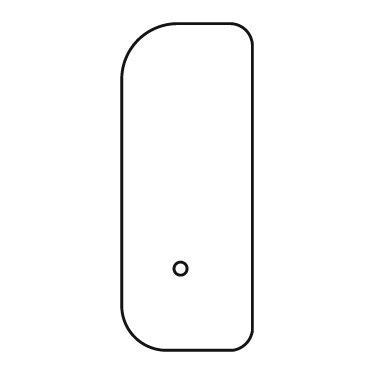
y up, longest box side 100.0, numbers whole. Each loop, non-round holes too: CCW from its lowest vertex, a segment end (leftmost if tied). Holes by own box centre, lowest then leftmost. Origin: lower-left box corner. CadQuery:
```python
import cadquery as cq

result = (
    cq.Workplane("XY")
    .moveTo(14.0, 0.0)
    .lineTo(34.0, 0.0)
    .threePointArc((38.0, 2.0), (40.0, 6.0))
    .lineTo(40.0, 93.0)
    .threePointArc((38.0, 98.0), (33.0, 100.0))
    .lineTo(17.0, 100.0)
    .threePointArc((5.0, 95.0), (0.0, 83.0))
    .lineTo(0.0, 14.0)
    .threePointArc((4.0, 4.0), (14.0, 0.0))
    .close()
    .moveTo(18.0, 25.0)
    .circle(2.0)
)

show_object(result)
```